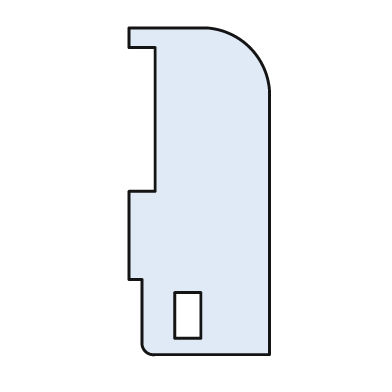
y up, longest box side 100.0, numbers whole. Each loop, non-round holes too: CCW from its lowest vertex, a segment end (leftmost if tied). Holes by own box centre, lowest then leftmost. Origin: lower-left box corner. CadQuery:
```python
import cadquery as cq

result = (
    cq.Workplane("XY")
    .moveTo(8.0, 0.0)
    .lineTo(43.0, 0.0)
    .lineTo(43.0, 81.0)
    .threePointArc((37.0, 94.0), (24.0, 100.0))
    .lineTo(0.0, 100.0)
    .lineTo(0.0, 94.0)
    .lineTo(8.0, 94.0)
    .lineTo(8.0, 50.0)
    .lineTo(0.0, 50.0)
    .lineTo(0.0, 23.0)
    .lineTo(4.0, 23.0)
    .lineTo(4.0, 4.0)
    .threePointArc((5.0, 1.0), (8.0, 0.0))
    .close()
    .moveTo(14.0, 5.0)
    .lineTo(22.0, 5.0)
    .lineTo(22.0, 19.0)
    .lineTo(14.0, 19.0)
    .close()
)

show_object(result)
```